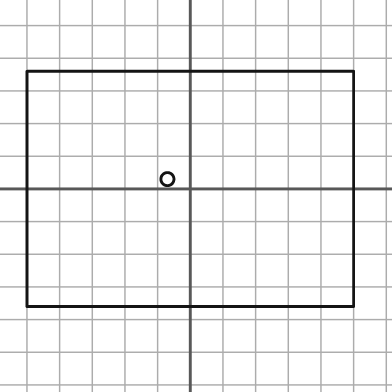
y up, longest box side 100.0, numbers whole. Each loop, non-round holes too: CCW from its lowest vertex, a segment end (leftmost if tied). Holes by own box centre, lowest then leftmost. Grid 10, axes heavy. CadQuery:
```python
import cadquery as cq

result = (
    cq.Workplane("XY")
    .moveTo(-50.0, -36.0)
    .lineTo(50.0, -36.0)
    .lineTo(50.0, 36.0)
    .lineTo(-50.0, 36.0)
    .close()
    .moveTo(-7.0, 3.0)
    .circle(2.0)
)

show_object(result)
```